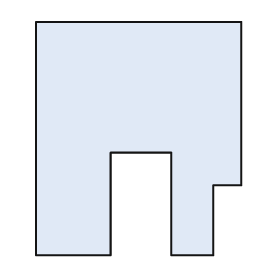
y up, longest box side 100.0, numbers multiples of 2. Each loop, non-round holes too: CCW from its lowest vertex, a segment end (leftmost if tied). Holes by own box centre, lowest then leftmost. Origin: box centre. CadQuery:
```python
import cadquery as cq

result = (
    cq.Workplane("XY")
    .moveTo(-44.0, -50.0)
    .lineTo(-12.0, -50.0)
    .lineTo(-12.0, -6.0)
    .lineTo(14.0, -6.0)
    .lineTo(14.0, -50.0)
    .lineTo(32.0, -50.0)
    .lineTo(32.0, -20.0)
    .lineTo(44.0, -20.0)
    .lineTo(44.0, 50.0)
    .lineTo(-44.0, 50.0)
    .close()
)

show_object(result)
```